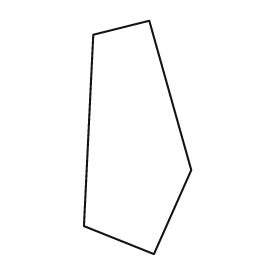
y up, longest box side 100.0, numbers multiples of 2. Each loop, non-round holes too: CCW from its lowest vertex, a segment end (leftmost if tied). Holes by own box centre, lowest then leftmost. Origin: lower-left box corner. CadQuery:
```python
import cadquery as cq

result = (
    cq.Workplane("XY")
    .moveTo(30.0, 0.0)
    .lineTo(46.0, 36.0)
    .lineTo(28.0, 100.0)
    .lineTo(4.0, 94.0)
    .lineTo(0.0, 12.0)
    .close()
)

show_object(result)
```